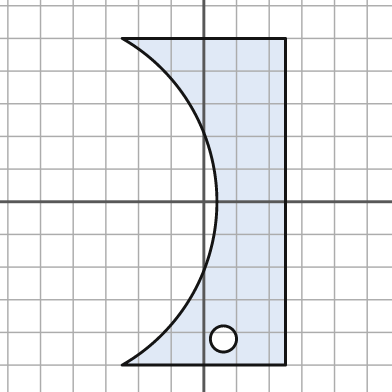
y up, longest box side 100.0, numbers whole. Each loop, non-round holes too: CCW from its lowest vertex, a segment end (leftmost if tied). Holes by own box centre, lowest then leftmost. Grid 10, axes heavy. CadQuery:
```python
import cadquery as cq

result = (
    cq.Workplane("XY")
    .moveTo(-25.0, -50.0)
    .lineTo(25.0, -50.0)
    .lineTo(25.0, 50.0)
    .lineTo(-25.0, 50.0)
    .threePointArc((4.0, 0.0), (-25.0, -50.0))
    .close()
    .moveTo(6.0, -42.0)
    .circle(4.0)
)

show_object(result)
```